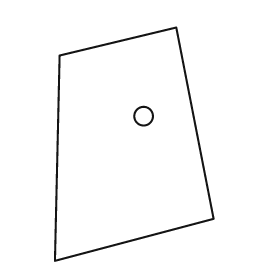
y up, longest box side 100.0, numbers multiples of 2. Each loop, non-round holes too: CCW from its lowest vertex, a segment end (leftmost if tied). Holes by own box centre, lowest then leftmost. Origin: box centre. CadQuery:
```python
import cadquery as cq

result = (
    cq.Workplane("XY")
    .moveTo(-34.0, -50.0)
    .lineTo(34.0, -32.0)
    .lineTo(18.0, 50.0)
    .lineTo(-32.0, 38.0)
    .close()
    .moveTo(4.0, 12.0)
    .circle(4.0)
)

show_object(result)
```